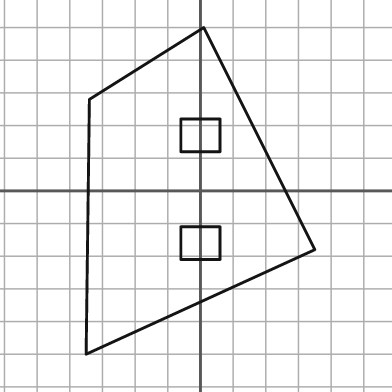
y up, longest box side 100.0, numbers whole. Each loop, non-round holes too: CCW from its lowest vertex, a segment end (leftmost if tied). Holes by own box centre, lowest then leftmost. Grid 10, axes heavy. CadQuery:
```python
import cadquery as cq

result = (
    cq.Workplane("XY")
    .moveTo(-35.0, -50.0)
    .lineTo(35.0, -18.0)
    .lineTo(1.0, 50.0)
    .lineTo(-34.0, 28.0)
    .close()
    .moveTo(-6.0, -21.0)
    .lineTo(6.0, -21.0)
    .lineTo(6.0, -11.0)
    .lineTo(-6.0, -11.0)
    .close()
    .moveTo(-6.0, 12.0)
    .lineTo(6.0, 12.0)
    .lineTo(6.0, 22.0)
    .lineTo(-6.0, 22.0)
    .close()
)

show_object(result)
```